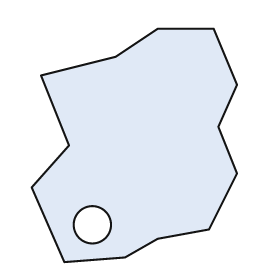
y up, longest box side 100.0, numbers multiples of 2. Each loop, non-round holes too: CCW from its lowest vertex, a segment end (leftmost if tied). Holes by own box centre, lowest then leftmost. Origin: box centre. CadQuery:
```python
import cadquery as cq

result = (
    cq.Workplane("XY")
    .moveTo(-30.0, -50.0)
    .lineTo(-4.0, -48.0)
    .lineTo(10.0, -40.0)
    .lineTo(32.0, -36.0)
    .lineTo(44.0, -12.0)
    .lineTo(36.0, 8.0)
    .lineTo(44.0, 26.0)
    .lineTo(34.0, 50.0)
    .lineTo(10.0, 50.0)
    .lineTo(-8.0, 38.0)
    .lineTo(-40.0, 30.0)
    .lineTo(-28.0, 0.0)
    .lineTo(-44.0, -18.0)
    .close()
    .moveTo(-18.0, -34.0)
    .circle(8.0)
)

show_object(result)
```